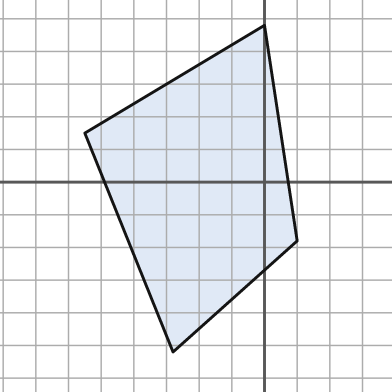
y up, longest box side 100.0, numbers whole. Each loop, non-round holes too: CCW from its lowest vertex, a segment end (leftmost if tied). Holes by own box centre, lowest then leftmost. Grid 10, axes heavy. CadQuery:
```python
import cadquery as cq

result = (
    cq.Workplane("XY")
    .moveTo(-28.0, -52.0)
    .lineTo(10.0, -18.0)
    .lineTo(0.0, 48.0)
    .lineTo(-55.0, 15.0)
    .close()
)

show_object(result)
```